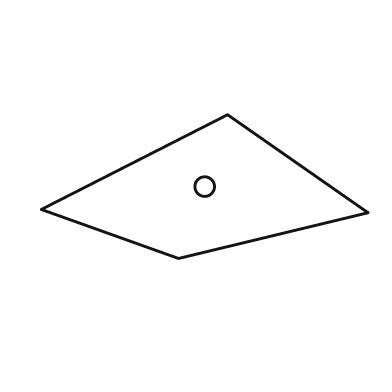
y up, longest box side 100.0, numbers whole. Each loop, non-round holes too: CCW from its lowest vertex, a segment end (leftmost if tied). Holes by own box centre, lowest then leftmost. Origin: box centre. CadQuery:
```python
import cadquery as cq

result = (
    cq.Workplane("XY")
    .moveTo(-8.0, -22.0)
    .lineTo(50.0, -8.0)
    .lineTo(7.0, 22.0)
    .lineTo(-50.0, -7.0)
    .close()
    .moveTo(0.0, 0.0)
    .circle(3.0)
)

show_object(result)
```